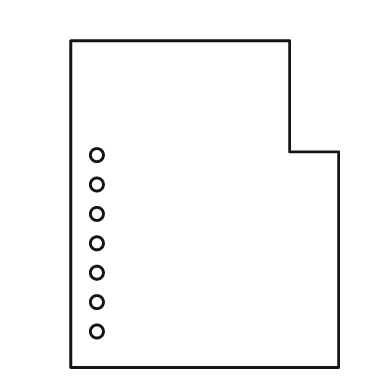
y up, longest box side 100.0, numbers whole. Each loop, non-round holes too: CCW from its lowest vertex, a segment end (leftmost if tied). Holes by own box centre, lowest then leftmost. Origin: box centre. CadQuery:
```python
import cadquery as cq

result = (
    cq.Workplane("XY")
    .moveTo(-41.0, -50.0)
    .lineTo(41.0, -50.0)
    .lineTo(41.0, 16.0)
    .lineTo(26.0, 16.0)
    .lineTo(26.0, 50.0)
    .lineTo(-41.0, 50.0)
    .close()
    .moveTo(-33.0, -39.0)
    .circle(2.0)
    .moveTo(-33.0, -30.0)
    .circle(2.0)
    .moveTo(-33.0, -21.0)
    .circle(2.0)
    .moveTo(-33.0, -12.0)
    .circle(2.0)
    .moveTo(-33.0, -3.0)
    .circle(2.0)
    .moveTo(-33.0, 6.0)
    .circle(2.0)
    .moveTo(-33.0, 15.0)
    .circle(2.0)
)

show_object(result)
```